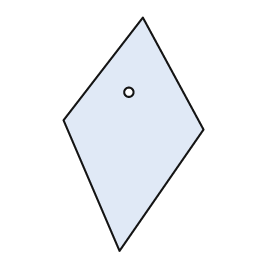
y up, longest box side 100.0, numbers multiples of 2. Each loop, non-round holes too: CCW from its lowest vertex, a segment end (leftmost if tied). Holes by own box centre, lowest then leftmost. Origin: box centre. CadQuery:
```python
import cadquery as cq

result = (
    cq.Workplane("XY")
    .moveTo(-6.0, -50.0)
    .lineTo(30.0, 2.0)
    .lineTo(4.0, 50.0)
    .lineTo(-30.0, 6.0)
    .close()
    .moveTo(-2.0, 18.0)
    .circle(2.0)
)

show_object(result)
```